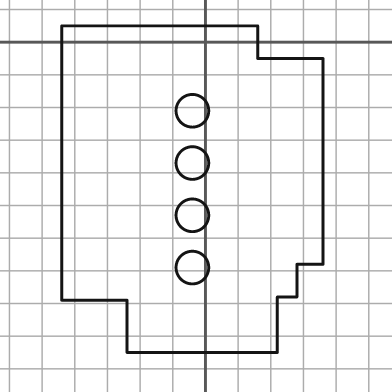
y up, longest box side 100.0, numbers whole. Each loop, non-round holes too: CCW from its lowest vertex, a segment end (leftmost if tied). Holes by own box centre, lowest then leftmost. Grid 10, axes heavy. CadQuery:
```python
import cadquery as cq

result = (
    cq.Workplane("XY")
    .moveTo(-24.0, -95.0)
    .lineTo(22.0, -95.0)
    .lineTo(22.0, -78.0)
    .lineTo(28.0, -78.0)
    .lineTo(28.0, -68.0)
    .lineTo(36.0, -68.0)
    .lineTo(36.0, -5.0)
    .lineTo(16.0, -5.0)
    .lineTo(16.0, 5.0)
    .lineTo(-44.0, 5.0)
    .lineTo(-44.0, -79.0)
    .lineTo(-24.0, -79.0)
    .close()
    .moveTo(-4.0, -69.0)
    .circle(5.0)
    .moveTo(-4.0, -53.0)
    .circle(5.0)
    .moveTo(-4.0, -37.0)
    .circle(5.0)
    .moveTo(-4.0, -21.0)
    .circle(5.0)
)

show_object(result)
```